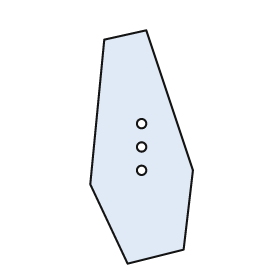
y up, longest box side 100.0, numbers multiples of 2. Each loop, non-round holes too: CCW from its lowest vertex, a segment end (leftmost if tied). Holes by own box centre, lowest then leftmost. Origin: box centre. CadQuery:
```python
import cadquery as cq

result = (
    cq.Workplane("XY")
    .moveTo(-6.0, -50.0)
    .lineTo(18.0, -44.0)
    .lineTo(22.0, -10.0)
    .lineTo(2.0, 50.0)
    .lineTo(-16.0, 46.0)
    .lineTo(-22.0, -16.0)
    .close()
    .moveTo(0.0, -10.0)
    .circle(2.0)
    .moveTo(0.0, 0.0)
    .circle(2.0)
    .moveTo(0.0, 10.0)
    .circle(2.0)
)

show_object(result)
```